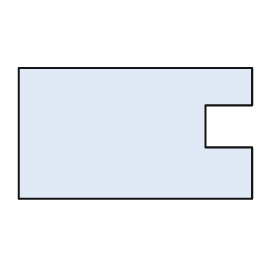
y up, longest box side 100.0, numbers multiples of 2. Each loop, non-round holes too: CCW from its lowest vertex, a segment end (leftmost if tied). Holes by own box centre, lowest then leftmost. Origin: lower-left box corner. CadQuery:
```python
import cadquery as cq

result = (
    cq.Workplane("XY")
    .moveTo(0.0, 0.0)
    .lineTo(100.0, 0.0)
    .lineTo(100.0, 22.0)
    .lineTo(80.0, 22.0)
    .lineTo(80.0, 40.0)
    .lineTo(100.0, 40.0)
    .lineTo(100.0, 56.0)
    .lineTo(0.0, 56.0)
    .close()
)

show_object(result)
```